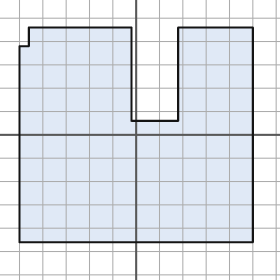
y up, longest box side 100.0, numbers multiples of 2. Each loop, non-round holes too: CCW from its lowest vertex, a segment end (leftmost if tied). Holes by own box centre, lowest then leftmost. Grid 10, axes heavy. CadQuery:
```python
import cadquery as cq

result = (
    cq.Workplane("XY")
    .moveTo(-50.0, -46.0)
    .lineTo(50.0, -46.0)
    .lineTo(50.0, 46.0)
    .lineTo(18.0, 46.0)
    .lineTo(18.0, 6.0)
    .lineTo(-2.0, 6.0)
    .lineTo(-2.0, 46.0)
    .lineTo(-46.0, 46.0)
    .lineTo(-46.0, 38.0)
    .lineTo(-50.0, 38.0)
    .close()
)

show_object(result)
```